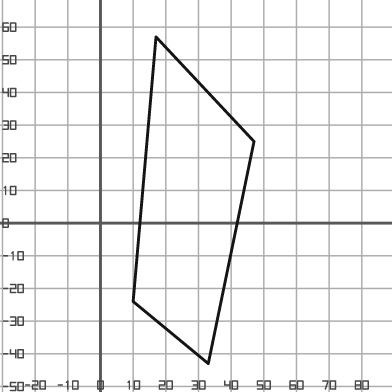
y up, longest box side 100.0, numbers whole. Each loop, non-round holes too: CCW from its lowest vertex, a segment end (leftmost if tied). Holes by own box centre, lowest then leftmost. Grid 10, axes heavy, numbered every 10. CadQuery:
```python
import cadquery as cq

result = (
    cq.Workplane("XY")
    .moveTo(33.0, -43.0)
    .lineTo(47.0, 25.0)
    .lineTo(17.0, 57.0)
    .lineTo(10.0, -24.0)
    .close()
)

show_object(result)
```